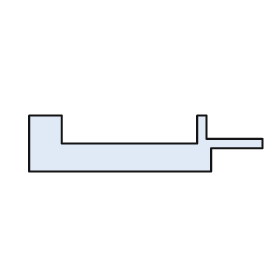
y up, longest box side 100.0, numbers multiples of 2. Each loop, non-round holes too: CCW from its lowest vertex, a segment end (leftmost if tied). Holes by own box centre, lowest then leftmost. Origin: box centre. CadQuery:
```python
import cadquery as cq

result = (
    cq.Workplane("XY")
    .moveTo(-50.0, -12.0)
    .lineTo(28.0, -12.0)
    .lineTo(28.0, -2.0)
    .lineTo(50.0, -2.0)
    .lineTo(50.0, 2.0)
    .lineTo(26.0, 2.0)
    .lineTo(26.0, 12.0)
    .lineTo(22.0, 12.0)
    .lineTo(22.0, 0.0)
    .lineTo(-36.0, 0.0)
    .lineTo(-36.0, 12.0)
    .lineTo(-50.0, 12.0)
    .close()
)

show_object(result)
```